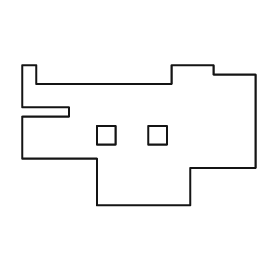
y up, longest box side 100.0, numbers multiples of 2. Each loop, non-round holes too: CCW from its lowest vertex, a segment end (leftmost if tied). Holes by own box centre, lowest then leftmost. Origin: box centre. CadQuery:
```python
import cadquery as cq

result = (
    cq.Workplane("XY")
    .moveTo(-18.0, -30.0)
    .lineTo(22.0, -30.0)
    .lineTo(22.0, -14.0)
    .lineTo(50.0, -14.0)
    .lineTo(50.0, 26.0)
    .lineTo(32.0, 26.0)
    .lineTo(32.0, 30.0)
    .lineTo(14.0, 30.0)
    .lineTo(14.0, 22.0)
    .lineTo(-44.0, 22.0)
    .lineTo(-44.0, 30.0)
    .lineTo(-50.0, 30.0)
    .lineTo(-50.0, 12.0)
    .lineTo(-30.0, 12.0)
    .lineTo(-30.0, 8.0)
    .lineTo(-50.0, 8.0)
    .lineTo(-50.0, -10.0)
    .lineTo(-18.0, -10.0)
    .close()
    .moveTo(-18.0, -4.0)
    .lineTo(-10.0, -4.0)
    .lineTo(-10.0, 4.0)
    .lineTo(-18.0, 4.0)
    .close()
    .moveTo(4.0, -4.0)
    .lineTo(12.0, -4.0)
    .lineTo(12.0, 4.0)
    .lineTo(4.0, 4.0)
    .close()
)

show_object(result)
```